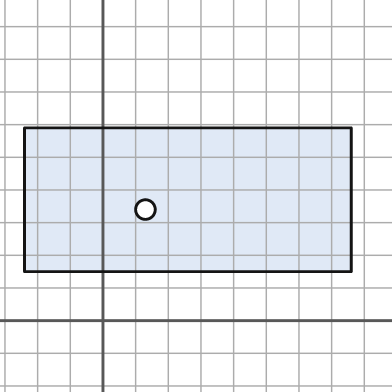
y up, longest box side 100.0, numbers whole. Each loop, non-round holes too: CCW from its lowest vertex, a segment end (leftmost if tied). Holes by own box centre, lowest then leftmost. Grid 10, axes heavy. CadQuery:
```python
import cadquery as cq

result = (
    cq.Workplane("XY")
    .moveTo(-24.0, 15.0)
    .lineTo(76.0, 15.0)
    .lineTo(76.0, 59.0)
    .lineTo(-24.0, 59.0)
    .close()
    .moveTo(13.0, 34.0)
    .circle(3.0)
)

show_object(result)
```